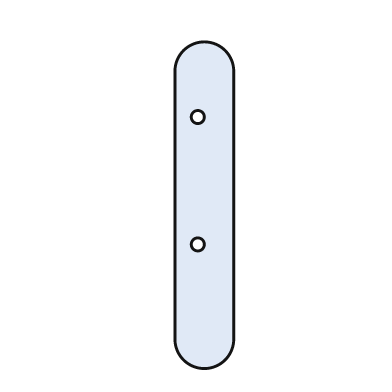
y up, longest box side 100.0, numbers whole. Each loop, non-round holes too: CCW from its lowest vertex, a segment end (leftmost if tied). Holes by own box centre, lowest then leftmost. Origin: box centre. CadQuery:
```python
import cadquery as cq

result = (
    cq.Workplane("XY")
    .moveTo(-9.0, -41.0)
    .threePointArc((0.0, -50.0), (9.0, -41.0))
    .lineTo(9.0, 41.0)
    .threePointArc((0.0, 50.0), (-9.0, 41.0))
    .close()
    .moveTo(-2.0, -12.0)
    .circle(2.0)
    .moveTo(-2.0, 27.0)
    .circle(2.0)
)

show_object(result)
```